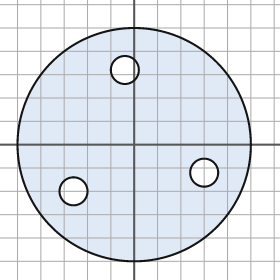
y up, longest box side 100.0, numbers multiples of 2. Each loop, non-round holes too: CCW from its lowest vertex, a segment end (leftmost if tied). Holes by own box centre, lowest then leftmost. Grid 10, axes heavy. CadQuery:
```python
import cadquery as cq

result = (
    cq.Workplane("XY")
    .moveTo(0.0, 0.0)
    .circle(50.0)
    .moveTo(-26.0, -20.0)
    .circle(6.0)
    .moveTo(30.0, -12.0)
    .circle(6.0)
    .moveTo(-4.0, 32.0)
    .circle(6.0)
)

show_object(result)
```